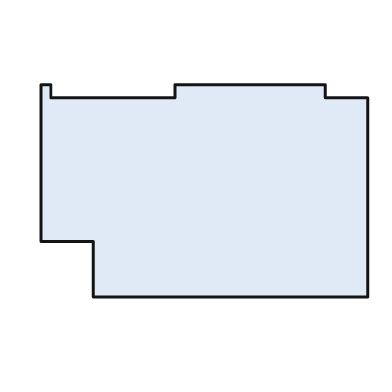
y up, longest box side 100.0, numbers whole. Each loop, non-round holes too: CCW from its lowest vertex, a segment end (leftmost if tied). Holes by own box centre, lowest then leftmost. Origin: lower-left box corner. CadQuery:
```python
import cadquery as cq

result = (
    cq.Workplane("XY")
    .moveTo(16.0, 0.0)
    .lineTo(100.0, 0.0)
    .lineTo(100.0, 61.0)
    .lineTo(87.0, 61.0)
    .lineTo(87.0, 65.0)
    .lineTo(41.0, 65.0)
    .lineTo(41.0, 61.0)
    .lineTo(3.0, 61.0)
    .lineTo(3.0, 65.0)
    .lineTo(0.0, 65.0)
    .lineTo(0.0, 17.0)
    .lineTo(16.0, 17.0)
    .close()
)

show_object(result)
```